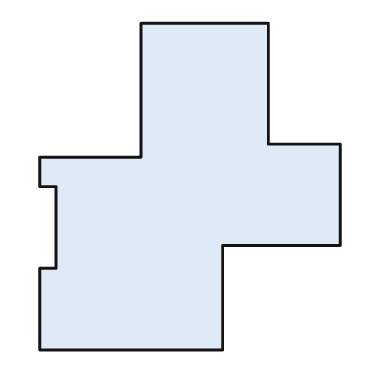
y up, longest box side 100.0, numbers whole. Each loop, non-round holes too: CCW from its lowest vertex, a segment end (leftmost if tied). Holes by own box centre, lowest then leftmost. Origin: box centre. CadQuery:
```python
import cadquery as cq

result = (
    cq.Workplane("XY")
    .moveTo(-46.0, -50.0)
    .lineTo(10.0, -50.0)
    .lineTo(10.0, -18.0)
    .lineTo(46.0, -18.0)
    .lineTo(46.0, 13.0)
    .lineTo(24.0, 13.0)
    .lineTo(24.0, 50.0)
    .lineTo(-15.0, 50.0)
    .lineTo(-15.0, 9.0)
    .lineTo(-46.0, 9.0)
    .lineTo(-46.0, 0.0)
    .lineTo(-41.0, 0.0)
    .lineTo(-41.0, -25.0)
    .lineTo(-46.0, -25.0)
    .close()
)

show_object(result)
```